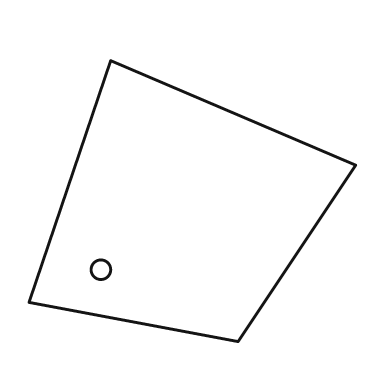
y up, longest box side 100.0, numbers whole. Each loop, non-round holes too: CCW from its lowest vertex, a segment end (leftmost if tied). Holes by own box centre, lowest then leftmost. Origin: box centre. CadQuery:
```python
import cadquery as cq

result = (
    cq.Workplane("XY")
    .moveTo(14.0, -43.0)
    .lineTo(50.0, 11.0)
    .lineTo(-25.0, 43.0)
    .lineTo(-50.0, -31.0)
    .close()
    .moveTo(-28.0, -21.0)
    .circle(3.0)
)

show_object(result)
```